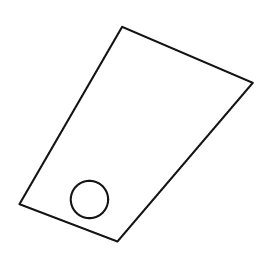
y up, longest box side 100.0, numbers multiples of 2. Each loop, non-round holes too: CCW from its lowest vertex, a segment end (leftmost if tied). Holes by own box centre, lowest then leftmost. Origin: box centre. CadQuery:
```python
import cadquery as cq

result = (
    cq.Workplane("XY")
    .moveTo(-8.0, -46.0)
    .lineTo(50.0, 22.0)
    .lineTo(-6.0, 46.0)
    .lineTo(-50.0, -30.0)
    .close()
    .moveTo(-20.0, -28.0)
    .circle(8.0)
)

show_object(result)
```